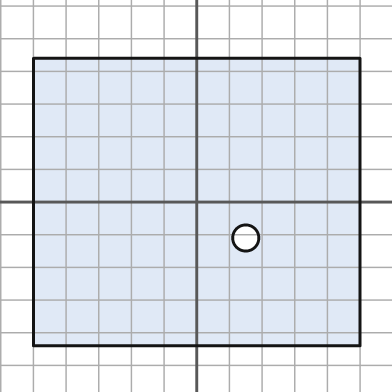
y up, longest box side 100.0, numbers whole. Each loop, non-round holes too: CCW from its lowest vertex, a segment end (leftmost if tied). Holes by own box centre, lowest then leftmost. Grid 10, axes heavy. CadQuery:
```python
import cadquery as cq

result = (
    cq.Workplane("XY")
    .moveTo(-50.0, -44.0)
    .lineTo(50.0, -44.0)
    .lineTo(50.0, 44.0)
    .lineTo(-50.0, 44.0)
    .close()
    .moveTo(15.0, -11.0)
    .circle(4.0)
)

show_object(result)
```